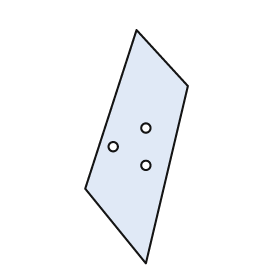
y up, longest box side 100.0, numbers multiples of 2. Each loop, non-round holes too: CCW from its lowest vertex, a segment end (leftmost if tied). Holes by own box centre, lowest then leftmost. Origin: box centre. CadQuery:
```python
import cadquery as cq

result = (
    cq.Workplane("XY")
    .moveTo(4.0, -50.0)
    .lineTo(22.0, 26.0)
    .lineTo(0.0, 50.0)
    .lineTo(-22.0, -18.0)
    .close()
    .moveTo(4.0, -8.0)
    .circle(2.0)
    .moveTo(-10.0, 0.0)
    .circle(2.0)
    .moveTo(4.0, 8.0)
    .circle(2.0)
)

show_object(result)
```